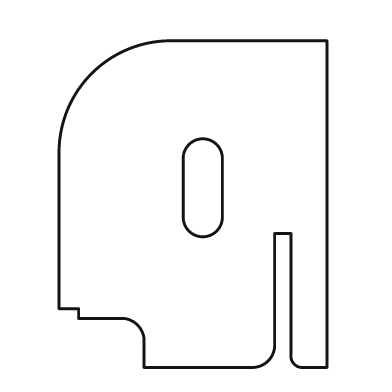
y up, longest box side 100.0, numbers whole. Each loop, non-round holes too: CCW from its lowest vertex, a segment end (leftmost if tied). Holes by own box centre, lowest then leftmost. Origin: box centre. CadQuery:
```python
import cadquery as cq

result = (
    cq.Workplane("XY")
    .moveTo(-15.0, -50.0)
    .lineTo(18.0, -50.0)
    .threePointArc((23.0, -48.0), (25.0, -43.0))
    .lineTo(25.0, -9.0)
    .lineTo(30.0, -9.0)
    .lineTo(30.0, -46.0)
    .threePointArc((31.0, -49.0), (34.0, -50.0))
    .lineTo(41.0, -50.0)
    .lineTo(41.0, 50.0)
    .lineTo(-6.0, 50.0)
    .threePointArc((-31.0, 40.0), (-41.0, 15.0))
    .lineTo(-41.0, -32.0)
    .lineTo(-35.0, -32.0)
    .lineTo(-35.0, -35.0)
    .lineTo(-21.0, -35.0)
    .threePointArc((-17.0, -37.0), (-15.0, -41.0))
    .close()
    .moveTo(-3.0, -4.0)
    .threePointArc((3.0, -10.0), (9.0, -4.0))
    .lineTo(9.0, 14.0)
    .threePointArc((3.0, 20.0), (-3.0, 14.0))
    .close()
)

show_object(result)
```